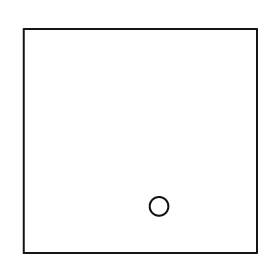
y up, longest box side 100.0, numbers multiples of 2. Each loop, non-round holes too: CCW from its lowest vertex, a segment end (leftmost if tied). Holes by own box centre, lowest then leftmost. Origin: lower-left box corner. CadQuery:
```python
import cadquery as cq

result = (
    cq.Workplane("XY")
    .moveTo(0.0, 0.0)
    .lineTo(100.0, 0.0)
    .lineTo(100.0, 96.0)
    .lineTo(0.0, 96.0)
    .close()
    .moveTo(58.0, 20.0)
    .circle(4.0)
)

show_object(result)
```